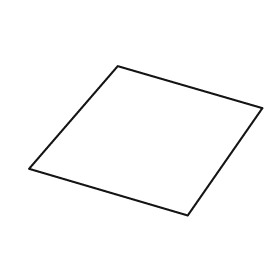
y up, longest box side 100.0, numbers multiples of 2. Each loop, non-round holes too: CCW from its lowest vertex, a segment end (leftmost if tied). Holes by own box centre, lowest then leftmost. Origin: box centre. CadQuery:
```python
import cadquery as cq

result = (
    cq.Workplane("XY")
    .moveTo(18.0, -32.0)
    .lineTo(50.0, 14.0)
    .lineTo(-12.0, 32.0)
    .lineTo(-50.0, -12.0)
    .close()
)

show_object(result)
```